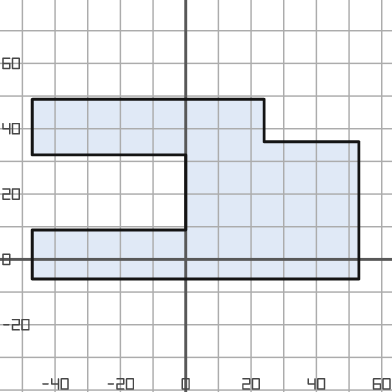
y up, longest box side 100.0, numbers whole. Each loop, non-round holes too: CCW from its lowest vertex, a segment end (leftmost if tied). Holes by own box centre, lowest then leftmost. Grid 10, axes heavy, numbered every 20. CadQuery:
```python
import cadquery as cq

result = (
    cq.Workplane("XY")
    .moveTo(-47.0, -6.0)
    .lineTo(53.0, -6.0)
    .lineTo(53.0, 36.0)
    .lineTo(24.0, 36.0)
    .lineTo(24.0, 49.0)
    .lineTo(-47.0, 49.0)
    .lineTo(-47.0, 32.0)
    .lineTo(0.0, 32.0)
    .lineTo(0.0, 9.0)
    .lineTo(-47.0, 9.0)
    .close()
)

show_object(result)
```